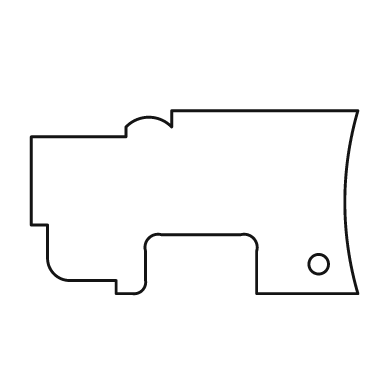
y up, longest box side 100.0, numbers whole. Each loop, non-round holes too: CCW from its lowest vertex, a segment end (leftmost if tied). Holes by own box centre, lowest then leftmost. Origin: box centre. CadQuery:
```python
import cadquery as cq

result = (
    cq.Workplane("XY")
    .moveTo(-24.0, -28.0)
    .lineTo(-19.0, -28.0)
    .threePointArc((-16.0, -27.0), (-15.0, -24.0))
    .lineTo(-15.0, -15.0)
    .threePointArc((-14.0, -11.0), (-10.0, -10.0))
    .lineTo(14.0, -10.0)
    .threePointArc((18.0, -11.0), (19.0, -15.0))
    .lineTo(19.0, -28.0)
    .lineTo(50.0, -28.0)
    .threePointArc((46.0, 0.0), (50.0, 28.0))
    .lineTo(-7.0, 28.0)
    .lineTo(-7.0, 23.0)
    .threePointArc((-14.0, 26.0), (-21.0, 23.0))
    .lineTo(-21.0, 20.0)
    .lineTo(-50.0, 20.0)
    .lineTo(-50.0, -7.0)
    .lineTo(-45.0, -7.0)
    .lineTo(-45.0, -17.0)
    .threePointArc((-43.0, -22.0), (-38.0, -24.0))
    .lineTo(-24.0, -24.0)
    .close()
    .moveTo(38.0, -19.0)
    .circle(3.0)
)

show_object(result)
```